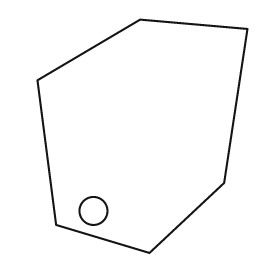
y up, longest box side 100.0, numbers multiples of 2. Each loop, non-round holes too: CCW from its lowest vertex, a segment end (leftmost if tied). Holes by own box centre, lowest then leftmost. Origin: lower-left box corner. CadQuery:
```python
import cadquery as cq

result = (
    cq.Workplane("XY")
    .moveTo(48.0, 0.0)
    .lineTo(80.0, 30.0)
    .lineTo(90.0, 96.0)
    .lineTo(44.0, 100.0)
    .lineTo(0.0, 74.0)
    .lineTo(8.0, 12.0)
    .close()
    .moveTo(24.0, 18.0)
    .circle(6.0)
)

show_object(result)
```